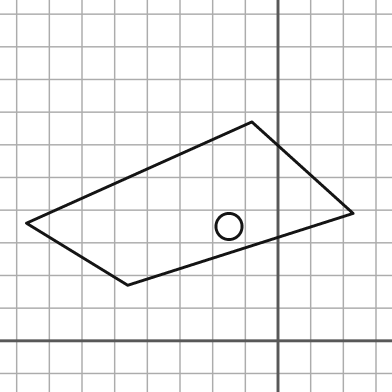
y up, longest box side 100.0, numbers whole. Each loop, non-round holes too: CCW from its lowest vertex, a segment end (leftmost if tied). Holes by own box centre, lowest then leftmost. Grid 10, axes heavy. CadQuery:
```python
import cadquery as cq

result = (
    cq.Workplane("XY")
    .moveTo(-46.0, 17.0)
    .lineTo(23.0, 39.0)
    .lineTo(-8.0, 67.0)
    .lineTo(-77.0, 36.0)
    .close()
    .moveTo(-15.0, 35.0)
    .circle(4.0)
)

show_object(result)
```